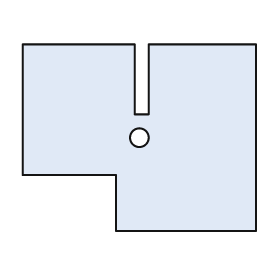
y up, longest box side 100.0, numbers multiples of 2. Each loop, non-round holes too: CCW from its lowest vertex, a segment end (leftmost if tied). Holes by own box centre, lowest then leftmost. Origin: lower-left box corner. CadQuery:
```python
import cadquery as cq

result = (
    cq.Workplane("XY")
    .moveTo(40.0, 0.0)
    .lineTo(100.0, 0.0)
    .lineTo(100.0, 80.0)
    .lineTo(54.0, 80.0)
    .lineTo(54.0, 50.0)
    .lineTo(48.0, 50.0)
    .lineTo(48.0, 80.0)
    .lineTo(0.0, 80.0)
    .lineTo(0.0, 24.0)
    .lineTo(40.0, 24.0)
    .close()
    .moveTo(50.0, 40.0)
    .circle(4.0)
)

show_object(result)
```